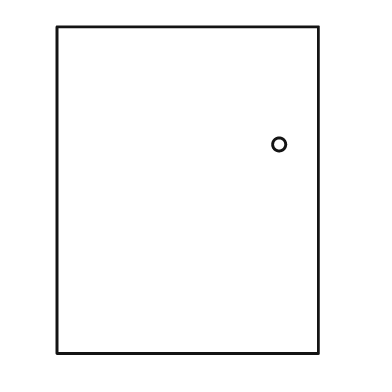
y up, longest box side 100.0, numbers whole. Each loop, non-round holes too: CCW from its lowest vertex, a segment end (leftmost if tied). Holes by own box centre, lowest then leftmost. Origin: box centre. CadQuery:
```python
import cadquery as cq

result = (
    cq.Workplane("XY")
    .moveTo(-40.0, -50.0)
    .lineTo(40.0, -50.0)
    .lineTo(40.0, 50.0)
    .lineTo(-40.0, 50.0)
    .close()
    .moveTo(28.0, 14.0)
    .circle(2.0)
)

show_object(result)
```